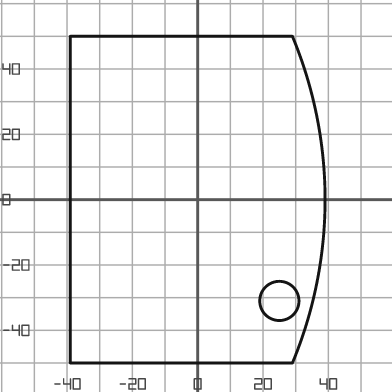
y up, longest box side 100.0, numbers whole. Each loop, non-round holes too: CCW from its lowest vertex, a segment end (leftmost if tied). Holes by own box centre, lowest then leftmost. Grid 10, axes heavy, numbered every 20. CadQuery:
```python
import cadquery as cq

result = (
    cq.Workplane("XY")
    .moveTo(-39.0, -50.0)
    .lineTo(29.0, -50.0)
    .threePointArc((39.0, 0.0), (29.0, 50.0))
    .lineTo(-39.0, 50.0)
    .close()
    .moveTo(25.0, -31.0)
    .circle(6.0)
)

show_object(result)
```